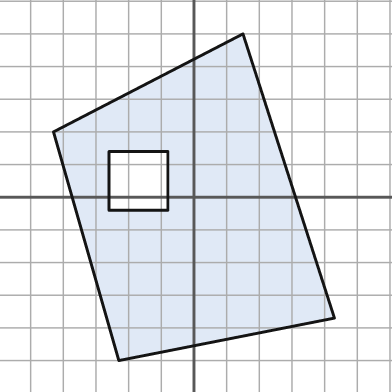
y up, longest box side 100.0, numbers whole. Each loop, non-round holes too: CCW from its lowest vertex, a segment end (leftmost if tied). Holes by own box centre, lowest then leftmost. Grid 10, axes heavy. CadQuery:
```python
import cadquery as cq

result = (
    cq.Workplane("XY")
    .moveTo(-23.0, -50.0)
    .lineTo(43.0, -37.0)
    .lineTo(15.0, 50.0)
    .lineTo(-43.0, 20.0)
    .close()
    .moveTo(-26.0, -4.0)
    .lineTo(-8.0, -4.0)
    .lineTo(-8.0, 14.0)
    .lineTo(-26.0, 14.0)
    .close()
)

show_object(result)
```